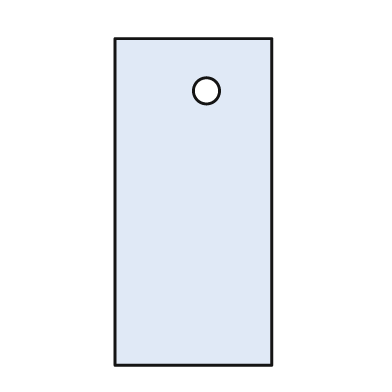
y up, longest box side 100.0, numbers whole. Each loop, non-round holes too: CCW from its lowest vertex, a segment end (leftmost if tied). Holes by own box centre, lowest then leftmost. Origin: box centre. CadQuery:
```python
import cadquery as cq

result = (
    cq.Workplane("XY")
    .moveTo(-24.0, -50.0)
    .lineTo(24.0, -50.0)
    .lineTo(24.0, 50.0)
    .lineTo(-24.0, 50.0)
    .close()
    .moveTo(4.0, 34.0)
    .circle(4.0)
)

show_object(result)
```